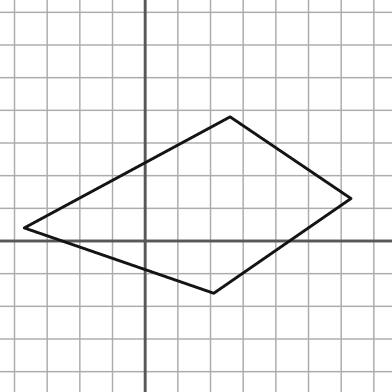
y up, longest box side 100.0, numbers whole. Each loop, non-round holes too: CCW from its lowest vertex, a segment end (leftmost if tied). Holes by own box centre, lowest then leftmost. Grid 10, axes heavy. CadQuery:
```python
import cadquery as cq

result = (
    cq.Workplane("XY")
    .moveTo(21.0, -16.0)
    .lineTo(63.0, 13.0)
    .lineTo(26.0, 38.0)
    .lineTo(-37.0, 4.0)
    .close()
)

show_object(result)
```